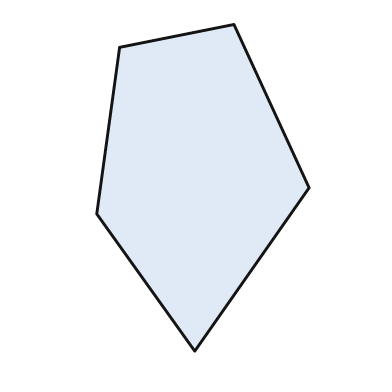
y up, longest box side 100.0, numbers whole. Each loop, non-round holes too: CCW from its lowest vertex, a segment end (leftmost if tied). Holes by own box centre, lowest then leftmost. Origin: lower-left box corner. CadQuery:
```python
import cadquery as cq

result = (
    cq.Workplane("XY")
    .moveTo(30.0, 0.0)
    .lineTo(65.0, 50.0)
    .lineTo(42.0, 100.0)
    .lineTo(7.0, 93.0)
    .lineTo(0.0, 42.0)
    .close()
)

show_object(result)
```